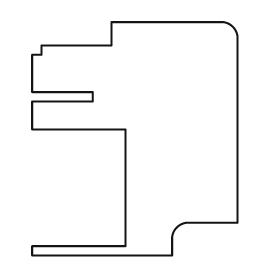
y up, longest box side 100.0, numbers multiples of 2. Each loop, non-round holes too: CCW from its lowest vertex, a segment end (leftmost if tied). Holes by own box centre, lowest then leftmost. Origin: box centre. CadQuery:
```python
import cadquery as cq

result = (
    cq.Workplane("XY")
    .moveTo(-44.0, -50.0)
    .lineTo(16.0, -50.0)
    .lineTo(16.0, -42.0)
    .threePointArc((18.0, -38.0), (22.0, -36.0))
    .lineTo(44.0, -36.0)
    .lineTo(44.0, 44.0)
    .threePointArc((42.0, 48.0), (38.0, 50.0))
    .lineTo(-10.0, 50.0)
    .lineTo(-10.0, 40.0)
    .lineTo(-40.0, 40.0)
    .lineTo(-40.0, 36.0)
    .lineTo(-44.0, 36.0)
    .lineTo(-44.0, 20.0)
    .lineTo(-18.0, 20.0)
    .lineTo(-18.0, 16.0)
    .lineTo(-44.0, 16.0)
    .lineTo(-44.0, 4.0)
    .lineTo(-4.0, 4.0)
    .lineTo(-4.0, -46.0)
    .lineTo(-44.0, -46.0)
    .close()
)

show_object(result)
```